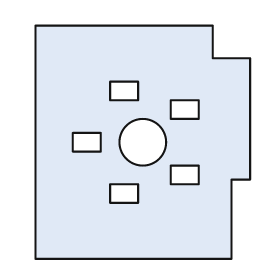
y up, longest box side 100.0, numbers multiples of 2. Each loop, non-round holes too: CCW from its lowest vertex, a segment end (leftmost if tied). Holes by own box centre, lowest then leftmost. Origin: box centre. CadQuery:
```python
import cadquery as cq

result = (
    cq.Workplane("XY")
    .moveTo(-46.0, -50.0)
    .lineTo(38.0, -50.0)
    .lineTo(38.0, -16.0)
    .lineTo(46.0, -16.0)
    .lineTo(46.0, 36.0)
    .lineTo(30.0, 36.0)
    .lineTo(30.0, 50.0)
    .lineTo(-46.0, 50.0)
    .close()
    .moveTo(-14.0, -26.0)
    .lineTo(-2.0, -26.0)
    .lineTo(-2.0, -18.0)
    .lineTo(-14.0, -18.0)
    .close()
    .moveTo(12.0, -18.0)
    .lineTo(24.0, -18.0)
    .lineTo(24.0, -10.0)
    .lineTo(12.0, -10.0)
    .close()
    .moveTo(-30.0, -4.0)
    .lineTo(-18.0, -4.0)
    .lineTo(-18.0, 4.0)
    .lineTo(-30.0, 4.0)
    .close()
    .moveTo(0.0, 0.0)
    .circle(10.0)
    .moveTo(12.0, 10.0)
    .lineTo(24.0, 10.0)
    .lineTo(24.0, 18.0)
    .lineTo(12.0, 18.0)
    .close()
    .moveTo(-14.0, 18.0)
    .lineTo(-2.0, 18.0)
    .lineTo(-2.0, 26.0)
    .lineTo(-14.0, 26.0)
    .close()
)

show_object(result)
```